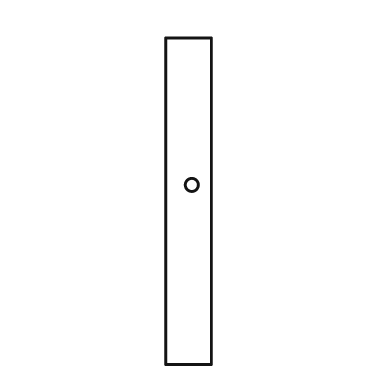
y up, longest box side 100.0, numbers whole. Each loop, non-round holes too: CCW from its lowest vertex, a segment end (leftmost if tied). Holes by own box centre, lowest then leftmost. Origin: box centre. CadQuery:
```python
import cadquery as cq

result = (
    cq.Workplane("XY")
    .moveTo(-7.0, -50.0)
    .lineTo(7.0, -50.0)
    .lineTo(7.0, 50.0)
    .lineTo(-7.0, 50.0)
    .close()
    .moveTo(1.0, 5.0)
    .circle(2.0)
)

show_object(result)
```